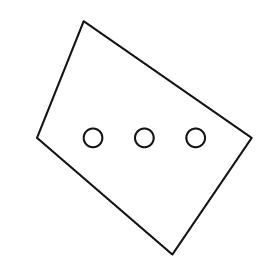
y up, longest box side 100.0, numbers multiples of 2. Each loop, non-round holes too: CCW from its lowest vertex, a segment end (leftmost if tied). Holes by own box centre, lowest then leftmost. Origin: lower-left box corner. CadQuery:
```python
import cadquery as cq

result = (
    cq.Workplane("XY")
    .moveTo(58.0, 0.0)
    .lineTo(92.0, 50.0)
    .lineTo(20.0, 100.0)
    .lineTo(0.0, 50.0)
    .close()
    .moveTo(24.0, 50.0)
    .circle(4.0)
    .moveTo(46.0, 50.0)
    .circle(4.0)
    .moveTo(68.0, 50.0)
    .circle(4.0)
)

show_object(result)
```